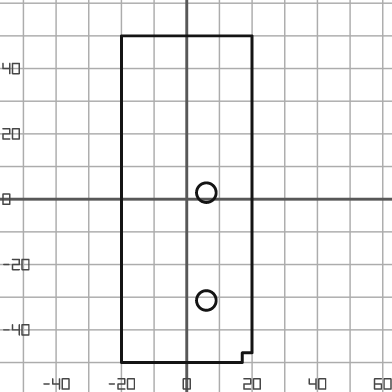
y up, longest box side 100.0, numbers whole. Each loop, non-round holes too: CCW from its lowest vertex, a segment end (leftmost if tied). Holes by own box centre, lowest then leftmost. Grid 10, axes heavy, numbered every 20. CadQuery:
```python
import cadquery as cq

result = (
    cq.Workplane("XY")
    .moveTo(-20.0, -50.0)
    .lineTo(17.0, -50.0)
    .lineTo(17.0, -47.0)
    .lineTo(20.0, -47.0)
    .lineTo(20.0, 50.0)
    .lineTo(-20.0, 50.0)
    .close()
    .moveTo(6.0, -31.0)
    .circle(3.0)
    .moveTo(6.0, 2.0)
    .circle(3.0)
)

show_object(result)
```